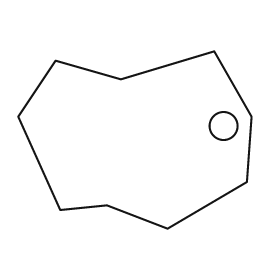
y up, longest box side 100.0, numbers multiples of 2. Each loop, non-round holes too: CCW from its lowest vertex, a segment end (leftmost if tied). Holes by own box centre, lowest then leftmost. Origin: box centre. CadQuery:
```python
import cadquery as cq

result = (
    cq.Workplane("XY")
    .moveTo(14.0, -38.0)
    .lineTo(48.0, -18.0)
    .lineTo(50.0, 10.0)
    .lineTo(34.0, 38.0)
    .lineTo(-6.0, 26.0)
    .lineTo(-34.0, 34.0)
    .lineTo(-50.0, 10.0)
    .lineTo(-32.0, -30.0)
    .lineTo(-12.0, -28.0)
    .close()
    .moveTo(38.0, 6.0)
    .circle(6.0)
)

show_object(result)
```